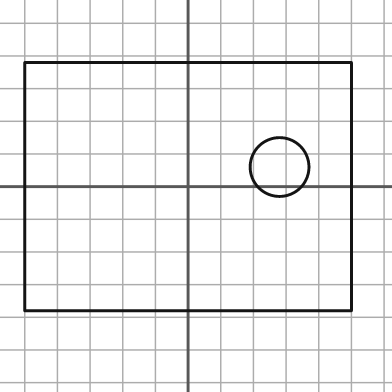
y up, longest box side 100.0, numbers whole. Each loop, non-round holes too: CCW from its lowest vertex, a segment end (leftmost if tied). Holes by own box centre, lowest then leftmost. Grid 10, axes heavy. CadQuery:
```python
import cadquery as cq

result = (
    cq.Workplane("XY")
    .moveTo(-50.0, -38.0)
    .lineTo(50.0, -38.0)
    .lineTo(50.0, 38.0)
    .lineTo(-50.0, 38.0)
    .close()
    .moveTo(28.0, 6.0)
    .circle(9.0)
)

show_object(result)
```